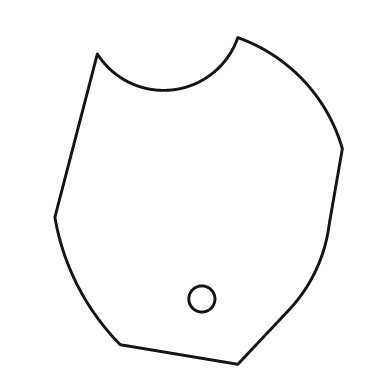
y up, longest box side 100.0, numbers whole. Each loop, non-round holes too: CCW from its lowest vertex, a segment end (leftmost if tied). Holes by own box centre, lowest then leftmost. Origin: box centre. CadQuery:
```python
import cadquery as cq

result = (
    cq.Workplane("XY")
    .moveTo(12.0, -50.0)
    .lineTo(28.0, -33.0)
    .threePointArc((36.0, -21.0), (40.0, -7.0))
    .lineTo(44.0, 16.0)
    .threePointArc((32.0, 37.0), (12.0, 50.0))
    .threePointArc((-8.0, 34.0), (-31.0, 45.0))
    .lineTo(-44.0, -5.0)
    .threePointArc((-37.0, -26.0), (-24.0, -44.0))
    .close()
    .moveTo(1.0, -30.0)
    .circle(4.0)
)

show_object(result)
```